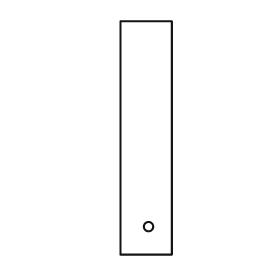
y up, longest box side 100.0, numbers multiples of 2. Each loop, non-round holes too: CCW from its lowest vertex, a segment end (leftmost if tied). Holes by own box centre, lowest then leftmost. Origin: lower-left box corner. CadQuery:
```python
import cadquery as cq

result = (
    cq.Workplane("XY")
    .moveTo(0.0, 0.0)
    .lineTo(22.0, 0.0)
    .lineTo(22.0, 100.0)
    .lineTo(0.0, 100.0)
    .close()
    .moveTo(12.0, 12.0)
    .circle(2.0)
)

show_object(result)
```